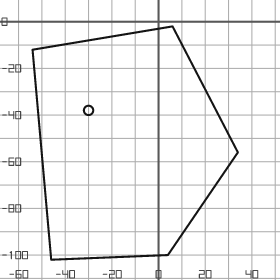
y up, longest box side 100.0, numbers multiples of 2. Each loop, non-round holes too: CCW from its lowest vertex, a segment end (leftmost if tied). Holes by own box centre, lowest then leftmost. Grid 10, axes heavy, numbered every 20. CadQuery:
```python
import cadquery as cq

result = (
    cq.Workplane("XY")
    .moveTo(-46.0, -102.0)
    .lineTo(4.0, -100.0)
    .lineTo(34.0, -56.0)
    .lineTo(6.0, -2.0)
    .lineTo(-54.0, -12.0)
    .close()
    .moveTo(-30.0, -38.0)
    .circle(2.0)
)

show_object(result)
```